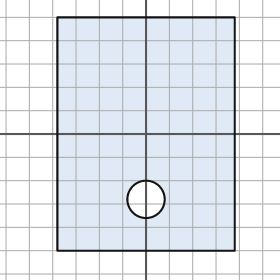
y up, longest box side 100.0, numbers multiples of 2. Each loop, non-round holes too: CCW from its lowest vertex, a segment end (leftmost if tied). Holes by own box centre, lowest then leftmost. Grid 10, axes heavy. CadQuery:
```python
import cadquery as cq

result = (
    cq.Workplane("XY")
    .moveTo(-38.0, -50.0)
    .lineTo(38.0, -50.0)
    .lineTo(38.0, 50.0)
    .lineTo(-38.0, 50.0)
    .close()
    .moveTo(0.0, -28.0)
    .circle(8.0)
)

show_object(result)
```